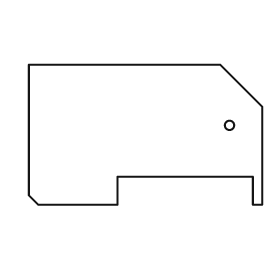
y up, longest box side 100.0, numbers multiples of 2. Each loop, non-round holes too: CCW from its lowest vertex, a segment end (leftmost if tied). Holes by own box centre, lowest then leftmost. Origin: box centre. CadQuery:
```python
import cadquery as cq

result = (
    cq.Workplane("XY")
    .moveTo(-46.0, -30.0)
    .lineTo(-12.0, -30.0)
    .lineTo(-12.0, -18.0)
    .lineTo(46.0, -18.0)
    .lineTo(46.0, -30.0)
    .lineTo(50.0, -30.0)
    .lineTo(50.0, 12.0)
    .lineTo(32.0, 30.0)
    .lineTo(-50.0, 30.0)
    .lineTo(-50.0, -26.0)
    .close()
    .moveTo(36.0, 4.0)
    .circle(2.0)
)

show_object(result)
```